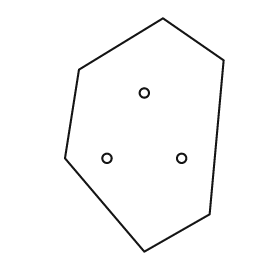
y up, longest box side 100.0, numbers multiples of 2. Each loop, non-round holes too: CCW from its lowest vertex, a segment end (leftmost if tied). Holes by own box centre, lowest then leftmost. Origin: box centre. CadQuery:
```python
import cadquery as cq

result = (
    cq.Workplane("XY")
    .moveTo(0.0, -50.0)
    .lineTo(28.0, -34.0)
    .lineTo(34.0, 32.0)
    .lineTo(8.0, 50.0)
    .lineTo(-28.0, 28.0)
    .lineTo(-34.0, -10.0)
    .close()
    .moveTo(-16.0, -10.0)
    .circle(2.0)
    .moveTo(16.0, -10.0)
    .circle(2.0)
    .moveTo(0.0, 18.0)
    .circle(2.0)
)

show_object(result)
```